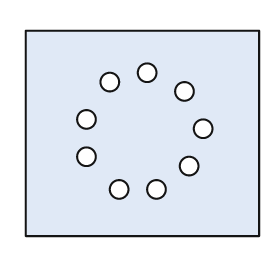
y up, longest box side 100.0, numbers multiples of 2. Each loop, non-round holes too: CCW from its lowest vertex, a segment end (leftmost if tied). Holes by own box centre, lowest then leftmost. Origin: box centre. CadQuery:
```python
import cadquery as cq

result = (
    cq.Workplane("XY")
    .moveTo(-50.0, -44.0)
    .lineTo(50.0, -44.0)
    .lineTo(50.0, 44.0)
    .lineTo(-50.0, 44.0)
    .close()
    .moveTo(-10.0, -24.0)
    .circle(4.0)
    .moveTo(6.0, -24.0)
    .circle(4.0)
    .moveTo(20.0, -14.0)
    .circle(4.0)
    .moveTo(-24.0, -10.0)
    .circle(4.0)
    .moveTo(26.0, 2.0)
    .circle(4.0)
    .moveTo(-24.0, 6.0)
    .circle(4.0)
    .moveTo(18.0, 18.0)
    .circle(4.0)
    .moveTo(-14.0, 22.0)
    .circle(4.0)
    .moveTo(2.0, 26.0)
    .circle(4.0)
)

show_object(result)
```